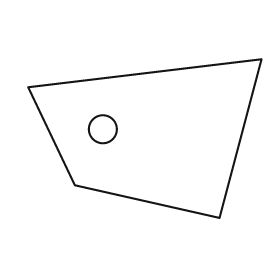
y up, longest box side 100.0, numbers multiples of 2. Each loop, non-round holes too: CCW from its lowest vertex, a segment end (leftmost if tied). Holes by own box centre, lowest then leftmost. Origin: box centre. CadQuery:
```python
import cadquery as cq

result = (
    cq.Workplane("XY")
    .moveTo(32.0, -34.0)
    .lineTo(50.0, 34.0)
    .lineTo(-50.0, 22.0)
    .lineTo(-30.0, -20.0)
    .close()
    .moveTo(-18.0, 4.0)
    .circle(6.0)
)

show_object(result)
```